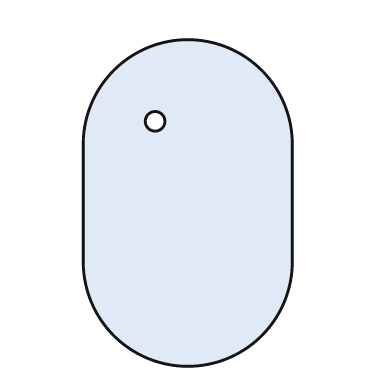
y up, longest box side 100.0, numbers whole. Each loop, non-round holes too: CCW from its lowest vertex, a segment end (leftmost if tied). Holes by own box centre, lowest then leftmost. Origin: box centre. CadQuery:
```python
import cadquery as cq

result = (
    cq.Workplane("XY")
    .moveTo(-32.0, -18.0)
    .threePointArc((0.0, -50.0), (32.0, -18.0))
    .lineTo(32.0, 18.0)
    .threePointArc((0.0, 50.0), (-32.0, 18.0))
    .close()
    .moveTo(-10.0, 25.0)
    .circle(3.0)
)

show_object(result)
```